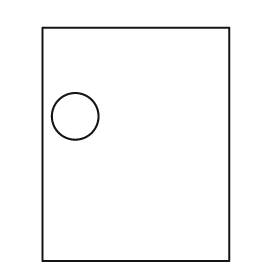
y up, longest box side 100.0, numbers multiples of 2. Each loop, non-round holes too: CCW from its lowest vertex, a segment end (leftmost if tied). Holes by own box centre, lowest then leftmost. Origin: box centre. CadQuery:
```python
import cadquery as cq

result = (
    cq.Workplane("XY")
    .moveTo(-40.0, -50.0)
    .lineTo(40.0, -50.0)
    .lineTo(40.0, 50.0)
    .lineTo(-40.0, 50.0)
    .close()
    .moveTo(-26.0, 12.0)
    .circle(10.0)
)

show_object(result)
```